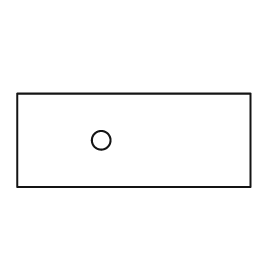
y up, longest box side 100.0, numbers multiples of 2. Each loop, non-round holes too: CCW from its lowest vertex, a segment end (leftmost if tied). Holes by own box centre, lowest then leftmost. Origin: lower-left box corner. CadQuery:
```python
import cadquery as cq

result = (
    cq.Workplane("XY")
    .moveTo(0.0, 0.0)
    .lineTo(100.0, 0.0)
    .lineTo(100.0, 40.0)
    .lineTo(0.0, 40.0)
    .close()
    .moveTo(36.0, 20.0)
    .circle(4.0)
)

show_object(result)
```